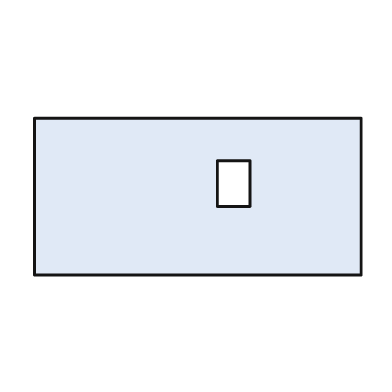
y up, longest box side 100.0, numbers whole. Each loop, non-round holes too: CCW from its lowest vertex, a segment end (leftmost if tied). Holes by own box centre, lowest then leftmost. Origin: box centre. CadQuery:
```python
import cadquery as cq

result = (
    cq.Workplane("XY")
    .moveTo(-50.0, -24.0)
    .lineTo(50.0, -24.0)
    .lineTo(50.0, 24.0)
    .lineTo(-50.0, 24.0)
    .close()
    .moveTo(6.0, -3.0)
    .lineTo(16.0, -3.0)
    .lineTo(16.0, 11.0)
    .lineTo(6.0, 11.0)
    .close()
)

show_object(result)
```